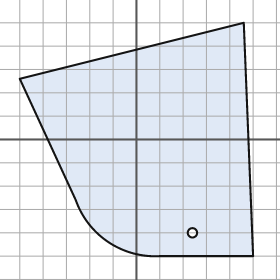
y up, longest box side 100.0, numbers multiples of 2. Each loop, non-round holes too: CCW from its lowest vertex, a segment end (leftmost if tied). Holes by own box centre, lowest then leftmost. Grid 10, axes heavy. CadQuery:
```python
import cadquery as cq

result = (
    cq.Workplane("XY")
    .moveTo(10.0, -50.0)
    .lineTo(50.0, -50.0)
    .lineTo(46.0, 50.0)
    .lineTo(-50.0, 26.0)
    .lineTo(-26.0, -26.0)
    .threePointArc((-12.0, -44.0), (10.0, -50.0))
    .close()
    .moveTo(24.0, -40.0)
    .circle(2.0)
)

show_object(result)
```